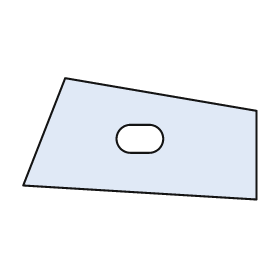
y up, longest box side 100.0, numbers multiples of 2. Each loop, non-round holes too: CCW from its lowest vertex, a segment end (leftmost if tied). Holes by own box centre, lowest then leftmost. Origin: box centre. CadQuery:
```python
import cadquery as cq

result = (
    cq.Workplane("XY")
    .moveTo(50.0, -26.0)
    .lineTo(50.0, 12.0)
    .lineTo(-32.0, 26.0)
    .lineTo(-50.0, -20.0)
    .close()
    .moveTo(-4.0, -6.0)
    .lineTo(4.0, -6.0)
    .threePointArc((10.0, 0.0), (4.0, 6.0))
    .lineTo(-4.0, 6.0)
    .threePointArc((-10.0, 0.0), (-4.0, -6.0))
    .close()
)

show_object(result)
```